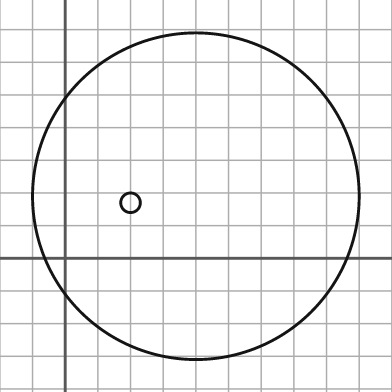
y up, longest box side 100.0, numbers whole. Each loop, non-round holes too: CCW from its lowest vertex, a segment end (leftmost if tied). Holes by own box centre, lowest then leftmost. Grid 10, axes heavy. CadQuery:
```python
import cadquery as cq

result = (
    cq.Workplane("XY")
    .moveTo(40.0, 19.0)
    .circle(50.0)
    .moveTo(20.0, 17.0)
    .circle(3.0)
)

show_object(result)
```